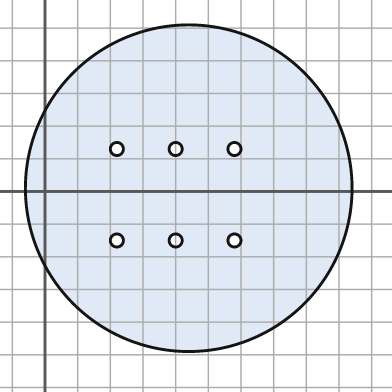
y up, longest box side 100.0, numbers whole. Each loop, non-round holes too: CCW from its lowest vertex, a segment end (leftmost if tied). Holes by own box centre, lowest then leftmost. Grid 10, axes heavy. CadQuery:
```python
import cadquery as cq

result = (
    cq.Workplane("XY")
    .moveTo(44.0, 1.0)
    .circle(50.0)
    .moveTo(22.0, -15.0)
    .circle(2.0)
    .moveTo(40.0, -15.0)
    .circle(2.0)
    .moveTo(58.0, -15.0)
    .circle(2.0)
    .moveTo(22.0, 13.0)
    .circle(2.0)
    .moveTo(40.0, 13.0)
    .circle(2.0)
    .moveTo(58.0, 13.0)
    .circle(2.0)
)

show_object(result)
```